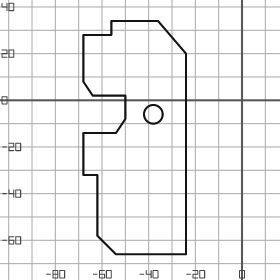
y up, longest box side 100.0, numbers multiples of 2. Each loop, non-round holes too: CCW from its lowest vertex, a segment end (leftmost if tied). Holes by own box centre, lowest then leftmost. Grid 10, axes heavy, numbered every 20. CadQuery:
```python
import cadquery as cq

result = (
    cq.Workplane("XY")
    .moveTo(-54.0, -66.0)
    .lineTo(-24.0, -66.0)
    .lineTo(-24.0, 20.0)
    .lineTo(-36.0, 34.0)
    .lineTo(-56.0, 34.0)
    .lineTo(-56.0, 28.0)
    .lineTo(-68.0, 28.0)
    .lineTo(-68.0, 8.0)
    .lineTo(-64.0, 2.0)
    .lineTo(-50.0, 2.0)
    .lineTo(-50.0, -8.0)
    .lineTo(-54.0, -14.0)
    .lineTo(-68.0, -14.0)
    .lineTo(-68.0, -32.0)
    .lineTo(-62.0, -32.0)
    .lineTo(-62.0, -58.0)
    .close()
    .moveTo(-38.0, -6.0)
    .circle(4.0)
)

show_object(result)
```